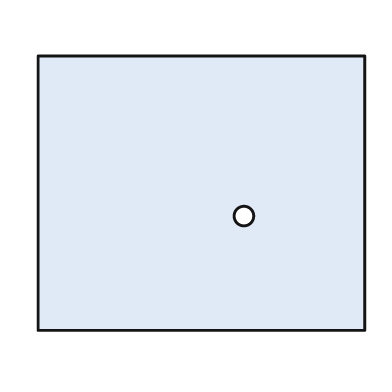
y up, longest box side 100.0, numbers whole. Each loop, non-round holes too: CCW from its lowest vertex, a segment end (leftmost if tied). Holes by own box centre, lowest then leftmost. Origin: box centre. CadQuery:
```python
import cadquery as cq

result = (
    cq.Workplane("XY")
    .moveTo(-50.0, -42.0)
    .lineTo(50.0, -42.0)
    .lineTo(50.0, 42.0)
    .lineTo(-50.0, 42.0)
    .close()
    .moveTo(13.0, -7.0)
    .circle(3.0)
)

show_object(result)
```